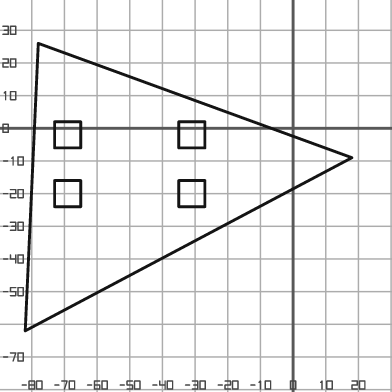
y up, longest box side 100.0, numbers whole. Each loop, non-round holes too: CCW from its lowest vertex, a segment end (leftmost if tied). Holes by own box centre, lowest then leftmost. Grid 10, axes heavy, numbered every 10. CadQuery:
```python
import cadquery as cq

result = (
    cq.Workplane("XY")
    .moveTo(-82.0, -62.0)
    .lineTo(18.0, -9.0)
    .lineTo(-78.0, 26.0)
    .close()
    .moveTo(-73.0, -24.0)
    .lineTo(-65.0, -24.0)
    .lineTo(-65.0, -16.0)
    .lineTo(-73.0, -16.0)
    .close()
    .moveTo(-35.0, -24.0)
    .lineTo(-27.0, -24.0)
    .lineTo(-27.0, -16.0)
    .lineTo(-35.0, -16.0)
    .close()
    .moveTo(-73.0, -6.0)
    .lineTo(-65.0, -6.0)
    .lineTo(-65.0, 2.0)
    .lineTo(-73.0, 2.0)
    .close()
    .moveTo(-35.0, -6.0)
    .lineTo(-27.0, -6.0)
    .lineTo(-27.0, 2.0)
    .lineTo(-35.0, 2.0)
    .close()
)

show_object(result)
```